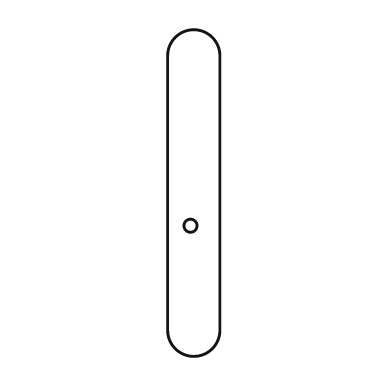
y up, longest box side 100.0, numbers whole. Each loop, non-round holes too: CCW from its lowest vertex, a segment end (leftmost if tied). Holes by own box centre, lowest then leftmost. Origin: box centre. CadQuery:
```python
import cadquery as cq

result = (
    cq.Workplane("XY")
    .moveTo(-8.0, -42.0)
    .threePointArc((0.0, -50.0), (8.0, -42.0))
    .lineTo(8.0, 42.0)
    .threePointArc((0.0, 50.0), (-8.0, 42.0))
    .close()
    .moveTo(-1.0, -10.0)
    .circle(2.0)
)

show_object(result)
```